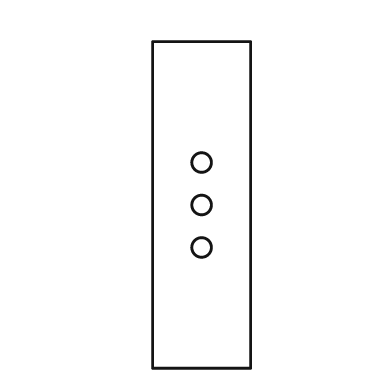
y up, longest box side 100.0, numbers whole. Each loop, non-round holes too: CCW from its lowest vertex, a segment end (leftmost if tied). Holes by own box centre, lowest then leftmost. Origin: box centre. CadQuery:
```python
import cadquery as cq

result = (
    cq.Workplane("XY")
    .moveTo(-15.0, -50.0)
    .lineTo(15.0, -50.0)
    .lineTo(15.0, 50.0)
    .lineTo(-15.0, 50.0)
    .close()
    .moveTo(0.0, -13.0)
    .circle(3.0)
    .moveTo(0.0, 0.0)
    .circle(3.0)
    .moveTo(0.0, 13.0)
    .circle(3.0)
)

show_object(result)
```